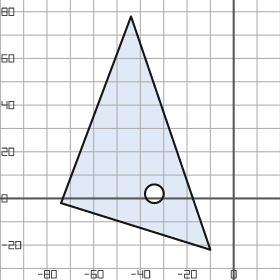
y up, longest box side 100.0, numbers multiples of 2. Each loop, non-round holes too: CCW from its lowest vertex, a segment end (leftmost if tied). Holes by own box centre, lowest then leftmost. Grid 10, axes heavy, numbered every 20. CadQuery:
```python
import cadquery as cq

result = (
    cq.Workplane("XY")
    .moveTo(-10.0, -22.0)
    .lineTo(-44.0, 78.0)
    .lineTo(-74.0, -2.0)
    .close()
    .moveTo(-34.0, 2.0)
    .circle(4.0)
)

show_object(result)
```